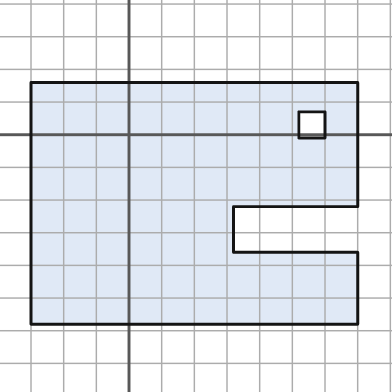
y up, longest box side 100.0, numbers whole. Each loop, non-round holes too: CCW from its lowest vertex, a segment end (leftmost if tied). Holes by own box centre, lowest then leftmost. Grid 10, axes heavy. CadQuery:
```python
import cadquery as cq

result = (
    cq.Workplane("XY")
    .moveTo(-30.0, -58.0)
    .lineTo(70.0, -58.0)
    .lineTo(70.0, -36.0)
    .lineTo(32.0, -36.0)
    .lineTo(32.0, -22.0)
    .lineTo(70.0, -22.0)
    .lineTo(70.0, 16.0)
    .lineTo(-30.0, 16.0)
    .close()
    .moveTo(52.0, -1.0)
    .lineTo(60.0, -1.0)
    .lineTo(60.0, 7.0)
    .lineTo(52.0, 7.0)
    .close()
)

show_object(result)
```